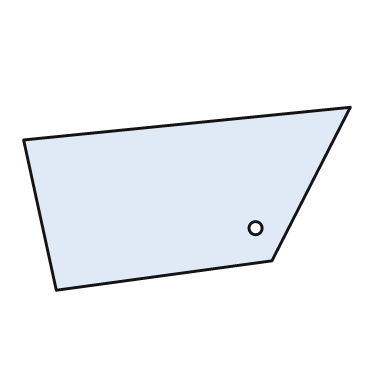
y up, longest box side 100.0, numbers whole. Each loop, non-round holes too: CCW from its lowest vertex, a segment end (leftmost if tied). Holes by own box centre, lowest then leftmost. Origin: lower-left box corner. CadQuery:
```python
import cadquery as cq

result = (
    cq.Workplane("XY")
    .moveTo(10.0, 0.0)
    .lineTo(76.0, 9.0)
    .lineTo(100.0, 56.0)
    .lineTo(0.0, 46.0)
    .close()
    .moveTo(71.0, 19.0)
    .circle(2.0)
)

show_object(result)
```